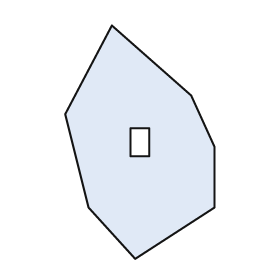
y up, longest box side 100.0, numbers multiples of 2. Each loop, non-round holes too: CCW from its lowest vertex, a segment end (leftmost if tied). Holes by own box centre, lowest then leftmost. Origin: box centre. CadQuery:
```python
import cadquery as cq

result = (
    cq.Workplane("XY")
    .moveTo(-2.0, -50.0)
    .lineTo(32.0, -28.0)
    .lineTo(32.0, -2.0)
    .lineTo(22.0, 20.0)
    .lineTo(-12.0, 50.0)
    .lineTo(-32.0, 12.0)
    .lineTo(-22.0, -28.0)
    .close()
    .moveTo(-4.0, -6.0)
    .lineTo(4.0, -6.0)
    .lineTo(4.0, 6.0)
    .lineTo(-4.0, 6.0)
    .close()
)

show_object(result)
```